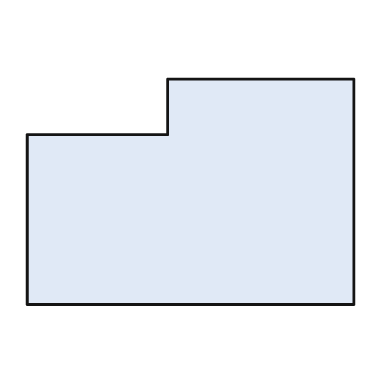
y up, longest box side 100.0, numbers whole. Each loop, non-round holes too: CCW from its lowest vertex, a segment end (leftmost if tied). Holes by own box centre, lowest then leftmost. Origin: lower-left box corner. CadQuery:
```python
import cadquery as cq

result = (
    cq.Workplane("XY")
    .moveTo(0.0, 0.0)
    .lineTo(100.0, 0.0)
    .lineTo(100.0, 69.0)
    .lineTo(43.0, 69.0)
    .lineTo(43.0, 52.0)
    .lineTo(0.0, 52.0)
    .close()
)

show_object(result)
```